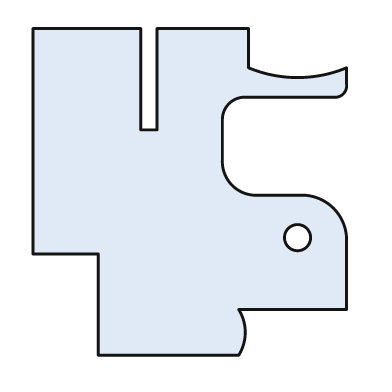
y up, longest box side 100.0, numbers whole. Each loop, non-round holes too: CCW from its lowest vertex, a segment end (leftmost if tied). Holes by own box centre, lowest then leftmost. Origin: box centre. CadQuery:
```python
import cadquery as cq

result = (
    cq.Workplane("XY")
    .moveTo(-28.0, -50.0)
    .lineTo(15.0, -50.0)
    .threePointArc((17.0, -43.0), (15.0, -36.0))
    .lineTo(48.0, -36.0)
    .lineTo(48.0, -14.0)
    .threePointArc((44.0, -5.0), (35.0, -1.0))
    .lineTo(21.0, -1.0)
    .threePointArc((13.0, 2.0), (10.0, 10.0))
    .lineTo(10.0, 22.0)
    .threePointArc((12.0, 27.0), (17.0, 29.0))
    .lineTo(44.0, 29.0)
    .threePointArc((47.0, 30.0), (48.0, 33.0))
    .lineTo(48.0, 38.0)
    .threePointArc((33.0, 35.0), (18.0, 38.0))
    .lineTo(18.0, 50.0)
    .lineTo(-10.0, 50.0)
    .lineTo(-10.0, 19.0)
    .lineTo(-15.0, 19.0)
    .lineTo(-15.0, 50.0)
    .lineTo(-48.0, 50.0)
    .lineTo(-48.0, -19.0)
    .lineTo(-28.0, -19.0)
    .close()
    .moveTo(33.0, -14.0)
    .circle(4.0)
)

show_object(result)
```